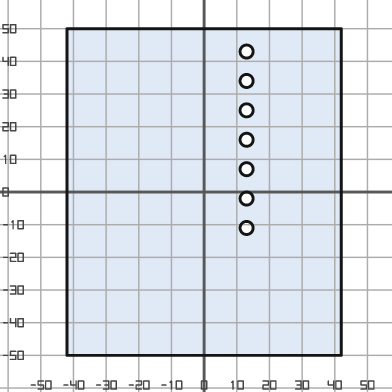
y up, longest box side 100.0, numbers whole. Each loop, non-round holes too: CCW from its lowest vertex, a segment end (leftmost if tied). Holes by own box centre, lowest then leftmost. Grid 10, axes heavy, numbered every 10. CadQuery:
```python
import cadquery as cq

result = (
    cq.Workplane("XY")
    .moveTo(-42.0, -50.0)
    .lineTo(42.0, -50.0)
    .lineTo(42.0, 50.0)
    .lineTo(-42.0, 50.0)
    .close()
    .moveTo(13.0, -11.0)
    .circle(2.0)
    .moveTo(13.0, -2.0)
    .circle(2.0)
    .moveTo(13.0, 7.0)
    .circle(2.0)
    .moveTo(13.0, 16.0)
    .circle(2.0)
    .moveTo(13.0, 25.0)
    .circle(2.0)
    .moveTo(13.0, 34.0)
    .circle(2.0)
    .moveTo(13.0, 43.0)
    .circle(2.0)
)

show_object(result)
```